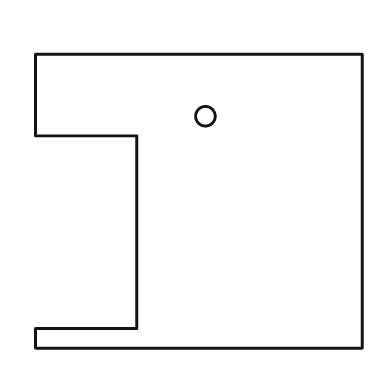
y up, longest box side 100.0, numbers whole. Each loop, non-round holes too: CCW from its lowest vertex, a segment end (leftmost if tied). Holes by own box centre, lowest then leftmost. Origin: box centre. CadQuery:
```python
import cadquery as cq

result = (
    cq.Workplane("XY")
    .moveTo(-50.0, -45.0)
    .lineTo(50.0, -45.0)
    .lineTo(50.0, 45.0)
    .lineTo(-50.0, 45.0)
    .lineTo(-50.0, 20.0)
    .lineTo(-19.0, 20.0)
    .lineTo(-19.0, -39.0)
    .lineTo(-50.0, -39.0)
    .close()
    .moveTo(2.0, 26.0)
    .circle(3.0)
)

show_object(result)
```